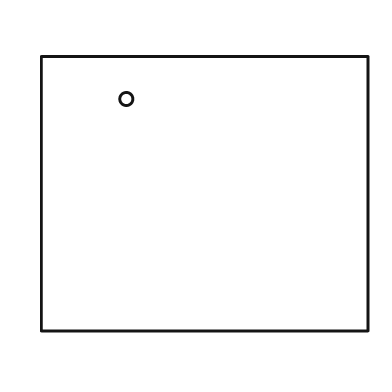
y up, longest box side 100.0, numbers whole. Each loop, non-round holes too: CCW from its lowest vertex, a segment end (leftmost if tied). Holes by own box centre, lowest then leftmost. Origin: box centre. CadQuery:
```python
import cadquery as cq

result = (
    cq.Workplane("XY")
    .moveTo(-50.0, -42.0)
    .lineTo(50.0, -42.0)
    .lineTo(50.0, 42.0)
    .lineTo(-50.0, 42.0)
    .close()
    .moveTo(-24.0, 29.0)
    .circle(2.0)
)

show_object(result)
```